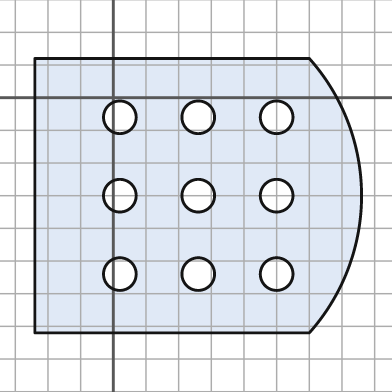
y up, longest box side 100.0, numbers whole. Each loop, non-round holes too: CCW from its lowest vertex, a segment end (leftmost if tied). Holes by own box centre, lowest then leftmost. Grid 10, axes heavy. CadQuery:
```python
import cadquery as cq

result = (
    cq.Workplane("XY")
    .moveTo(-24.0, -72.0)
    .lineTo(60.0, -72.0)
    .threePointArc((76.0, -30.0), (60.0, 12.0))
    .lineTo(-24.0, 12.0)
    .close()
    .moveTo(2.0, -54.0)
    .circle(5.0)
    .moveTo(26.0, -54.0)
    .circle(5.0)
    .moveTo(50.0, -54.0)
    .circle(5.0)
    .moveTo(2.0, -30.0)
    .circle(5.0)
    .moveTo(26.0, -30.0)
    .circle(5.0)
    .moveTo(50.0, -30.0)
    .circle(5.0)
    .moveTo(2.0, -6.0)
    .circle(5.0)
    .moveTo(26.0, -6.0)
    .circle(5.0)
    .moveTo(50.0, -6.0)
    .circle(5.0)
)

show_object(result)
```